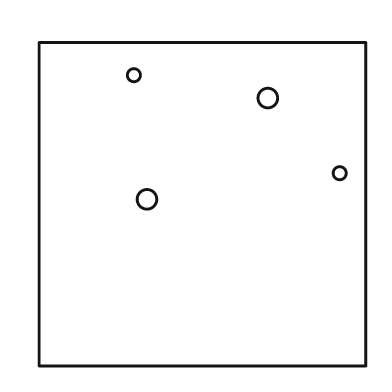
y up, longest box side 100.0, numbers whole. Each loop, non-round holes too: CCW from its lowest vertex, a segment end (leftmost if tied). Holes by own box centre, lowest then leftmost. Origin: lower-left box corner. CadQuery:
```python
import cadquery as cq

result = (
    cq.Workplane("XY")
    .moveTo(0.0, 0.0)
    .lineTo(100.0, 0.0)
    .lineTo(100.0, 99.0)
    .lineTo(0.0, 99.0)
    .close()
    .moveTo(33.0, 51.0)
    .circle(3.0)
    .moveTo(92.0, 59.0)
    .circle(2.0)
    .moveTo(70.0, 82.0)
    .circle(3.0)
    .moveTo(29.0, 89.0)
    .circle(2.0)
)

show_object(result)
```